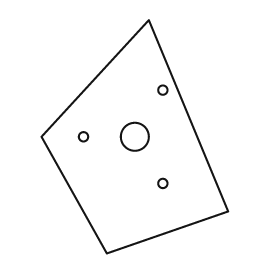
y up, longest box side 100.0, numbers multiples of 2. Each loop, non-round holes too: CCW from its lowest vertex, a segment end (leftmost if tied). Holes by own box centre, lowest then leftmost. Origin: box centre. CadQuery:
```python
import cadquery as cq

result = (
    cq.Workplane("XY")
    .moveTo(-12.0, -50.0)
    .lineTo(40.0, -32.0)
    .lineTo(6.0, 50.0)
    .lineTo(-40.0, 0.0)
    .close()
    .moveTo(12.0, -20.0)
    .circle(2.0)
    .moveTo(-22.0, 0.0)
    .circle(2.0)
    .moveTo(0.0, 0.0)
    .circle(6.0)
    .moveTo(12.0, 20.0)
    .circle(2.0)
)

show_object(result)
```